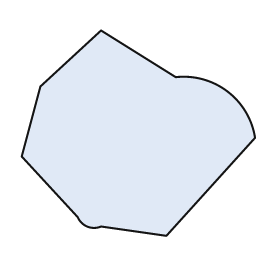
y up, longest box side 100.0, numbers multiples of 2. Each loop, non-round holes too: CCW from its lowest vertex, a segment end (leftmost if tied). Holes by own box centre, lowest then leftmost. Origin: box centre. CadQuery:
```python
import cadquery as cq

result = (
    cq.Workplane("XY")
    .moveTo(12.0, -44.0)
    .lineTo(50.0, -2.0)
    .threePointArc((38.0, 18.0), (16.0, 24.0))
    .lineTo(-16.0, 44.0)
    .lineTo(-42.0, 20.0)
    .lineTo(-50.0, -10.0)
    .lineTo(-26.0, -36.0)
    .threePointArc((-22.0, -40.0), (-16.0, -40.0))
    .close()
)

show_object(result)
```